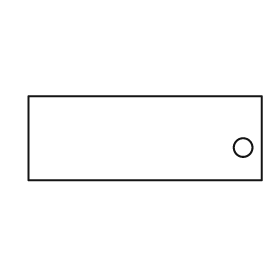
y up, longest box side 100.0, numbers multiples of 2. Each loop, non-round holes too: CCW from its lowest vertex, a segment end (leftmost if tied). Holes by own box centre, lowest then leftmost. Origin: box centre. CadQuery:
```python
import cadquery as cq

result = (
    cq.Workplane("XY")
    .moveTo(-50.0, -18.0)
    .lineTo(50.0, -18.0)
    .lineTo(50.0, 18.0)
    .lineTo(-50.0, 18.0)
    .close()
    .moveTo(42.0, -4.0)
    .circle(4.0)
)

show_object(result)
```